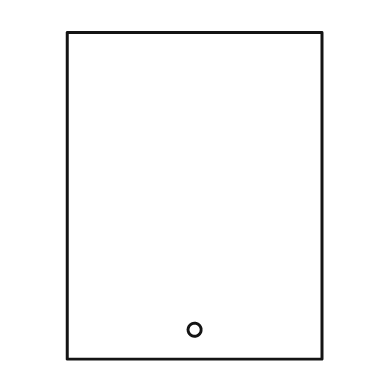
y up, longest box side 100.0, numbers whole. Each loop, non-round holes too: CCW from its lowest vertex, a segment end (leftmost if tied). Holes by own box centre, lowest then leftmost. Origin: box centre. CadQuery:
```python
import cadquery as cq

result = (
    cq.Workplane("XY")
    .moveTo(-39.0, -50.0)
    .lineTo(39.0, -50.0)
    .lineTo(39.0, 50.0)
    .lineTo(-39.0, 50.0)
    .close()
    .moveTo(0.0, -41.0)
    .circle(2.0)
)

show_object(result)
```